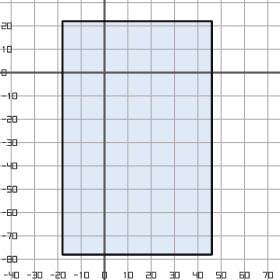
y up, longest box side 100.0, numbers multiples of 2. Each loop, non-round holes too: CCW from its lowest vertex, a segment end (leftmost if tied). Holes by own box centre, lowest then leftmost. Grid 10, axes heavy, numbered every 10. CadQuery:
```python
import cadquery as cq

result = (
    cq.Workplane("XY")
    .moveTo(-18.0, -78.0)
    .lineTo(46.0, -78.0)
    .lineTo(46.0, 22.0)
    .lineTo(-18.0, 22.0)
    .close()
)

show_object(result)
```